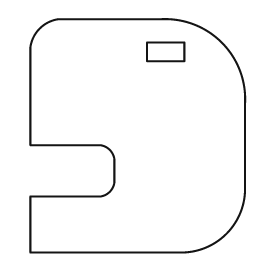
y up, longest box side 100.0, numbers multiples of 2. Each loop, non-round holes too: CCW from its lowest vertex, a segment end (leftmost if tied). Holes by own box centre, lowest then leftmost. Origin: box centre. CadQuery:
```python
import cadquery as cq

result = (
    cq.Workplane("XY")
    .moveTo(-46.0, -50.0)
    .lineTo(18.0, -50.0)
    .threePointArc((38.0, -42.0), (46.0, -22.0))
    .lineTo(46.0, 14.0)
    .threePointArc((36.0, 40.0), (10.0, 50.0))
    .lineTo(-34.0, 50.0)
    .threePointArc((-42.0, 46.0), (-46.0, 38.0))
    .lineTo(-46.0, -4.0)
    .lineTo(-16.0, -4.0)
    .threePointArc((-12.0, -6.0), (-10.0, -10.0))
    .lineTo(-10.0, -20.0)
    .threePointArc((-12.0, -24.0), (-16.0, -26.0))
    .lineTo(-46.0, -26.0)
    .close()
    .moveTo(4.0, 32.0)
    .lineTo(20.0, 32.0)
    .lineTo(20.0, 40.0)
    .lineTo(4.0, 40.0)
    .close()
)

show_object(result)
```